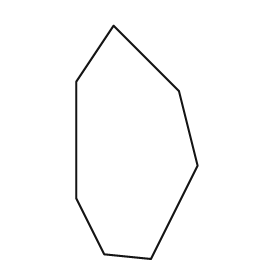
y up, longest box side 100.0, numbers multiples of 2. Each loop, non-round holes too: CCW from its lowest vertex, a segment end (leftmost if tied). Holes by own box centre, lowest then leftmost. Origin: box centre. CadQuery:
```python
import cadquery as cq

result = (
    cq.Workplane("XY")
    .moveTo(6.0, -50.0)
    .lineTo(26.0, -10.0)
    .lineTo(18.0, 22.0)
    .lineTo(-10.0, 50.0)
    .lineTo(-26.0, 26.0)
    .lineTo(-26.0, -24.0)
    .lineTo(-14.0, -48.0)
    .close()
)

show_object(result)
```